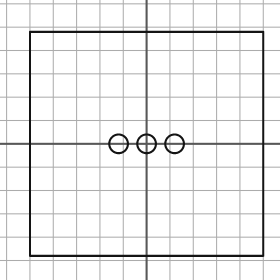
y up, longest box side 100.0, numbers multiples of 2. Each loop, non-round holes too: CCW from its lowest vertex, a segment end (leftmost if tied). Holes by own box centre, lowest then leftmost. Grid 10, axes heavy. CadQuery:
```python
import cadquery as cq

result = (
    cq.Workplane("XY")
    .moveTo(-50.0, -48.0)
    .lineTo(50.0, -48.0)
    .lineTo(50.0, 48.0)
    .lineTo(-50.0, 48.0)
    .close()
    .moveTo(-12.0, 0.0)
    .circle(4.0)
    .moveTo(0.0, 0.0)
    .circle(4.0)
    .moveTo(12.0, 0.0)
    .circle(4.0)
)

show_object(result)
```